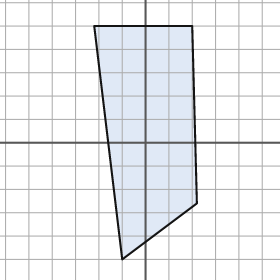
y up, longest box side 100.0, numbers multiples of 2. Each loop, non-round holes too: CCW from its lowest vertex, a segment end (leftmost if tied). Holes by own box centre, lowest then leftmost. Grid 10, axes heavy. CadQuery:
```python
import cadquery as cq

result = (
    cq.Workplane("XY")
    .moveTo(-10.0, -50.0)
    .lineTo(22.0, -26.0)
    .lineTo(20.0, 50.0)
    .lineTo(-22.0, 50.0)
    .close()
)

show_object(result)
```